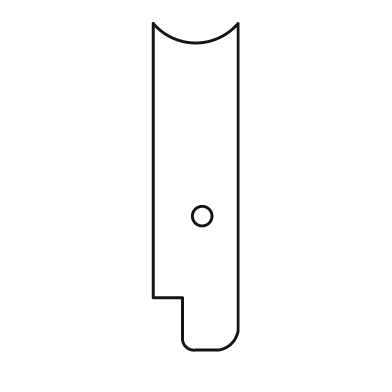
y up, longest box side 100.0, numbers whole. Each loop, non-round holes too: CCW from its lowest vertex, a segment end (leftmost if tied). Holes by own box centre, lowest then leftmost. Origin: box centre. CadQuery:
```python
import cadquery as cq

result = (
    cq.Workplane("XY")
    .moveTo(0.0, -50.0)
    .lineTo(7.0, -50.0)
    .threePointArc((11.0, -48.0), (13.0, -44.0))
    .lineTo(13.0, 50.0)
    .threePointArc((0.0, 44.0), (-13.0, 50.0))
    .lineTo(-13.0, -34.0)
    .lineTo(-4.0, -34.0)
    .lineTo(-4.0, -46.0)
    .threePointArc((-3.0, -49.0), (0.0, -50.0))
    .close()
    .moveTo(2.0, -9.0)
    .circle(3.0)
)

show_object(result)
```